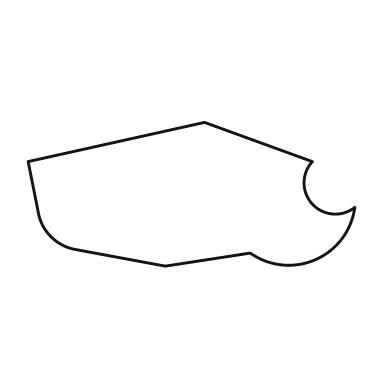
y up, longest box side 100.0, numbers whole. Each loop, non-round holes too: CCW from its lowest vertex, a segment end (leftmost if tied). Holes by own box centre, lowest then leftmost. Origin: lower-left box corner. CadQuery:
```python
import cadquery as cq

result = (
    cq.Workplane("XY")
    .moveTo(42.0, 0.0)
    .lineTo(68.0, 4.0)
    .threePointArc((88.0, 2.0), (100.0, 18.0))
    .threePointArc((87.0, 19.0), (87.0, 32.0))
    .lineTo(54.0, 44.0)
    .lineTo(0.0, 32.0)
    .lineTo(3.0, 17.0)
    .threePointArc((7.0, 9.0), (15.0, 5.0))
    .close()
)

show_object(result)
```